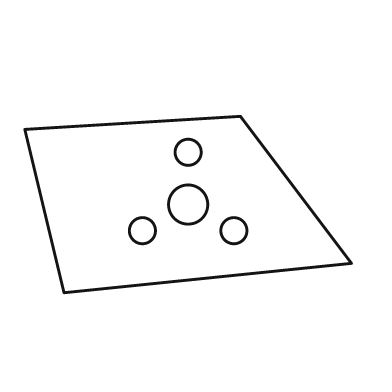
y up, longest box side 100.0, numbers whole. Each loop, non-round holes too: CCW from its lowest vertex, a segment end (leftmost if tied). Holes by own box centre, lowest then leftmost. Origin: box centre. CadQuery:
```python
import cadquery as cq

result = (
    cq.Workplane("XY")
    .moveTo(-38.0, -27.0)
    .lineTo(50.0, -18.0)
    .lineTo(16.0, 27.0)
    .lineTo(-50.0, 23.0)
    .close()
    .moveTo(-14.0, -8.0)
    .circle(4.0)
    .moveTo(14.0, -8.0)
    .circle(4.0)
    .moveTo(0.0, 0.0)
    .circle(6.0)
    .moveTo(0.0, 16.0)
    .circle(4.0)
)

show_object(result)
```